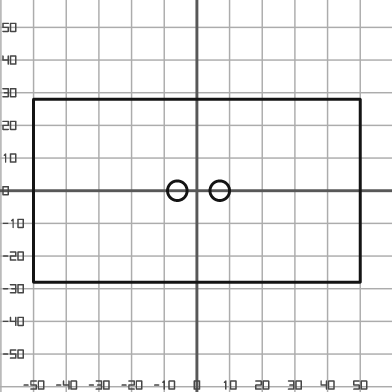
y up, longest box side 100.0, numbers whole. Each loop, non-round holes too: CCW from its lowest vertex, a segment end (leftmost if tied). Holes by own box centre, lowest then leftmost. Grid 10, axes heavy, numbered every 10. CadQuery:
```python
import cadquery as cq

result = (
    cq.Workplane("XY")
    .moveTo(-50.0, -28.0)
    .lineTo(50.0, -28.0)
    .lineTo(50.0, 28.0)
    .lineTo(-50.0, 28.0)
    .close()
    .moveTo(-6.0, 0.0)
    .circle(3.0)
    .moveTo(7.0, 0.0)
    .circle(3.0)
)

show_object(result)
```